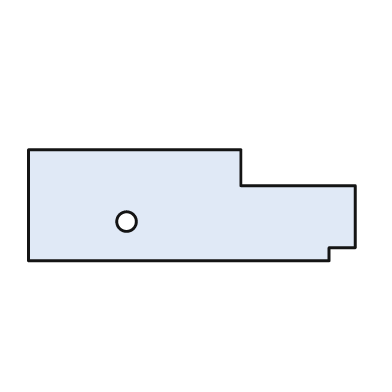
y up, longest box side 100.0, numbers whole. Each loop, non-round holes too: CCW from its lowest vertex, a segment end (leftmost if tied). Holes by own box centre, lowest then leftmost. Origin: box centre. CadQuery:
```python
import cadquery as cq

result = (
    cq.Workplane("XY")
    .moveTo(-50.0, -17.0)
    .lineTo(42.0, -17.0)
    .lineTo(42.0, -13.0)
    .lineTo(50.0, -13.0)
    .lineTo(50.0, 6.0)
    .lineTo(15.0, 6.0)
    .lineTo(15.0, 17.0)
    .lineTo(-50.0, 17.0)
    .close()
    .moveTo(-20.0, -5.0)
    .circle(3.0)
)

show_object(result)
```